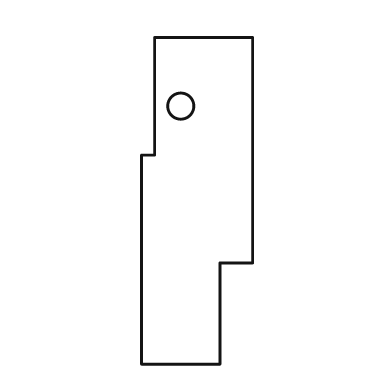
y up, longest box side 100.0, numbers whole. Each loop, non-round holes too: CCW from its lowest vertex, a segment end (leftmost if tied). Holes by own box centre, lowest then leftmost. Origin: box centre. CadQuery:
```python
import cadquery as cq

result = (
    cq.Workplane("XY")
    .moveTo(-17.0, -50.0)
    .lineTo(7.0, -50.0)
    .lineTo(7.0, -19.0)
    .lineTo(17.0, -19.0)
    .lineTo(17.0, 50.0)
    .lineTo(-13.0, 50.0)
    .lineTo(-13.0, 14.0)
    .lineTo(-17.0, 14.0)
    .close()
    .moveTo(-5.0, 29.0)
    .circle(4.0)
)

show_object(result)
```